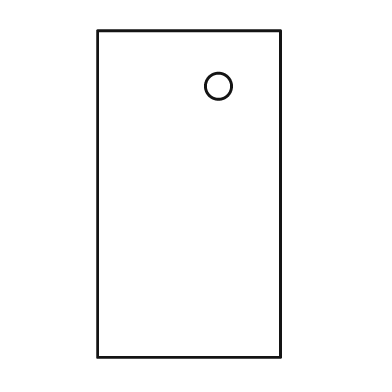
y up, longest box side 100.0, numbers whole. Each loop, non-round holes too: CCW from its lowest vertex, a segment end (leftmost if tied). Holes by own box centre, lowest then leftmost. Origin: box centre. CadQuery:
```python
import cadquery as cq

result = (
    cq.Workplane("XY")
    .moveTo(-28.0, -50.0)
    .lineTo(28.0, -50.0)
    .lineTo(28.0, 50.0)
    .lineTo(-28.0, 50.0)
    .close()
    .moveTo(9.0, 33.0)
    .circle(4.0)
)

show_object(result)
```